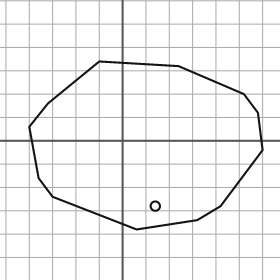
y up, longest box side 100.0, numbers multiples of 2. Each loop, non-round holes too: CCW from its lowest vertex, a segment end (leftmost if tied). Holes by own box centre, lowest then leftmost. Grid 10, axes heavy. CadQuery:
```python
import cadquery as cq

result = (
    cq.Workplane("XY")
    .moveTo(6.0, -38.0)
    .lineTo(32.0, -34.0)
    .lineTo(42.0, -28.0)
    .lineTo(60.0, -4.0)
    .lineTo(58.0, 12.0)
    .lineTo(52.0, 20.0)
    .lineTo(24.0, 32.0)
    .lineTo(-10.0, 34.0)
    .lineTo(-32.0, 16.0)
    .lineTo(-40.0, 6.0)
    .lineTo(-36.0, -16.0)
    .lineTo(-30.0, -24.0)
    .close()
    .moveTo(14.0, -28.0)
    .circle(2.0)
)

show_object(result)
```